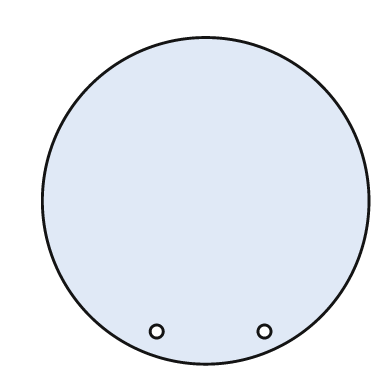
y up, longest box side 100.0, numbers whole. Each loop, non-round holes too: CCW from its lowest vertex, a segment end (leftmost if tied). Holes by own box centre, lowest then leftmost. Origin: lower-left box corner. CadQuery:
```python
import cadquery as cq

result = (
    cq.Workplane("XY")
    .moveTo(50.0, 50.0)
    .circle(50.0)
    .moveTo(35.0, 10.0)
    .circle(2.0)
    .moveTo(68.0, 10.0)
    .circle(2.0)
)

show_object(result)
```